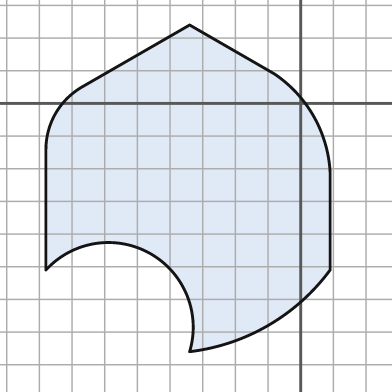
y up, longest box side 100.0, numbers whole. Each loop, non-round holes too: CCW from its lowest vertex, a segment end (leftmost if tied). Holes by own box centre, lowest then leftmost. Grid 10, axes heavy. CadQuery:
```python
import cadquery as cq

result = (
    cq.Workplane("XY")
    .moveTo(-34.0, -76.0)
    .threePointArc((-10.0, -68.0), (9.0, -51.0))
    .lineTo(9.0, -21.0)
    .threePointArc((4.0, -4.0), (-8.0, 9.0))
    .lineTo(-34.0, 24.0)
    .lineTo(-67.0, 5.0)
    .threePointArc((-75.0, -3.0), (-78.0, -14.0))
    .lineTo(-78.0, -51.0)
    .threePointArc((-46.0, -46.0), (-34.0, -76.0))
    .close()
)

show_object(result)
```